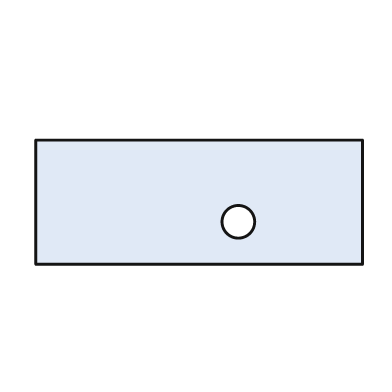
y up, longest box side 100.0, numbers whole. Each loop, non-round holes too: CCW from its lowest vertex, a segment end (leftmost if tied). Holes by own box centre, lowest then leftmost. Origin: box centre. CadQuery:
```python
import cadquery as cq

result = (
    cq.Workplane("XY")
    .moveTo(-50.0, -19.0)
    .lineTo(50.0, -19.0)
    .lineTo(50.0, 19.0)
    .lineTo(-50.0, 19.0)
    .close()
    .moveTo(12.0, -6.0)
    .circle(5.0)
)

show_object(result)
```